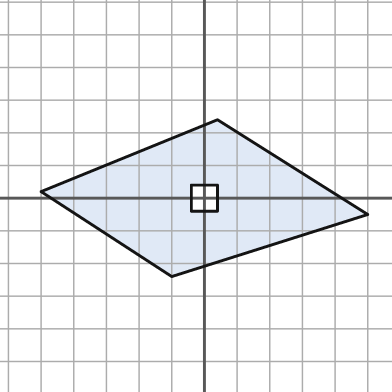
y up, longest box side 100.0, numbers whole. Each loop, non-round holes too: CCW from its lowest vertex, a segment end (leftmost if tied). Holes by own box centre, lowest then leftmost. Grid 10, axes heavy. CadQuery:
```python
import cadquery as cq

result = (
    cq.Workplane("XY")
    .moveTo(-10.0, -24.0)
    .lineTo(50.0, -5.0)
    .lineTo(4.0, 24.0)
    .lineTo(-50.0, 2.0)
    .close()
    .moveTo(-4.0, -4.0)
    .lineTo(4.0, -4.0)
    .lineTo(4.0, 4.0)
    .lineTo(-4.0, 4.0)
    .close()
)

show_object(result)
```